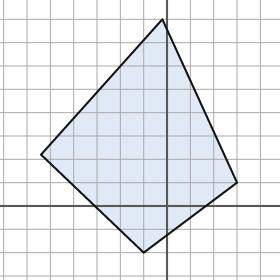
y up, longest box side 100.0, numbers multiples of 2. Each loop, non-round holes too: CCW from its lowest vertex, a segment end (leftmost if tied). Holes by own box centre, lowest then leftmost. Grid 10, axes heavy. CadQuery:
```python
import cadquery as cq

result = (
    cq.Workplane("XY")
    .moveTo(-10.0, -20.0)
    .lineTo(30.0, 10.0)
    .lineTo(-2.0, 80.0)
    .lineTo(-54.0, 22.0)
    .close()
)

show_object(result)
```